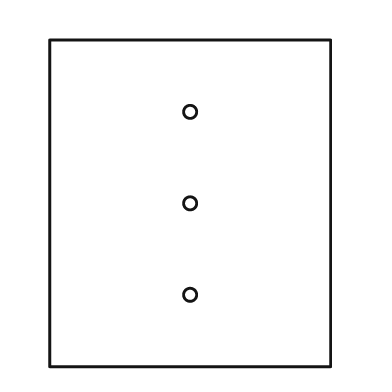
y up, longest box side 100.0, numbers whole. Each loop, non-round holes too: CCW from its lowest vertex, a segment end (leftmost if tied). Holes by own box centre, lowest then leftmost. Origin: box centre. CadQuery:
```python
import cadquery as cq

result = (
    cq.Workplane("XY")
    .moveTo(-43.0, -50.0)
    .lineTo(43.0, -50.0)
    .lineTo(43.0, 50.0)
    .lineTo(-43.0, 50.0)
    .close()
    .moveTo(0.0, -28.0)
    .circle(2.0)
    .moveTo(0.0, 0.0)
    .circle(2.0)
    .moveTo(0.0, 28.0)
    .circle(2.0)
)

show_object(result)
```